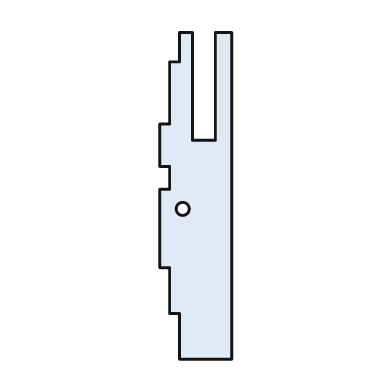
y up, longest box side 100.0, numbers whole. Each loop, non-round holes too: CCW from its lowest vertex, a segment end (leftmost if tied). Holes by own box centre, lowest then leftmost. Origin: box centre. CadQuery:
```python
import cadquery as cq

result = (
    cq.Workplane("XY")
    .moveTo(-5.0, -50.0)
    .lineTo(11.0, -50.0)
    .lineTo(11.0, 50.0)
    .lineTo(6.0, 50.0)
    .lineTo(6.0, 17.0)
    .lineTo(-1.0, 17.0)
    .lineTo(-1.0, 50.0)
    .lineTo(-5.0, 50.0)
    .lineTo(-5.0, 41.0)
    .lineTo(-8.0, 41.0)
    .lineTo(-8.0, 22.0)
    .lineTo(-11.0, 22.0)
    .lineTo(-11.0, 9.0)
    .lineTo(-8.0, 9.0)
    .lineTo(-8.0, 2.0)
    .lineTo(-11.0, 2.0)
    .lineTo(-11.0, -22.0)
    .lineTo(-8.0, -22.0)
    .lineTo(-8.0, -36.0)
    .lineTo(-5.0, -36.0)
    .close()
    .moveTo(-4.0, -4.0)
    .circle(2.0)
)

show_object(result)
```